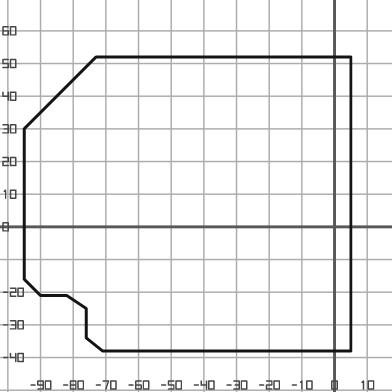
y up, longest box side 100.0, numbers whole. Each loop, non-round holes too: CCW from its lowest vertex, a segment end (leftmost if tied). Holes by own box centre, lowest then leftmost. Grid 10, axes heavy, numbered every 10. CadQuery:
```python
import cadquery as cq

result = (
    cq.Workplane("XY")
    .moveTo(-71.0, -38.0)
    .lineTo(5.0, -38.0)
    .lineTo(5.0, 52.0)
    .lineTo(-73.0, 52.0)
    .lineTo(-95.0, 30.0)
    .lineTo(-95.0, -16.0)
    .lineTo(-90.0, -21.0)
    .lineTo(-82.0, -21.0)
    .lineTo(-76.0, -25.0)
    .lineTo(-76.0, -34.0)
    .close()
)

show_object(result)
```